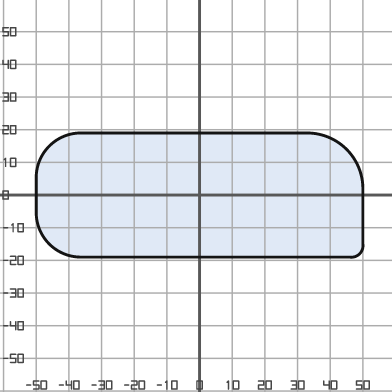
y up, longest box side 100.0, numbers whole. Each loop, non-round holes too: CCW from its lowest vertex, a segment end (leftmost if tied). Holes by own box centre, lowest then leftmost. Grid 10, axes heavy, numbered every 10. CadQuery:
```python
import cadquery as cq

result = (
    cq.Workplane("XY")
    .moveTo(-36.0, -19.0)
    .lineTo(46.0, -19.0)
    .threePointArc((49.0, -18.0), (50.0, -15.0))
    .lineTo(50.0, 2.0)
    .threePointArc((45.0, 14.0), (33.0, 19.0))
    .lineTo(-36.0, 19.0)
    .threePointArc((-46.0, 15.0), (-50.0, 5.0))
    .lineTo(-50.0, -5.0)
    .threePointArc((-46.0, -15.0), (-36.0, -19.0))
    .close()
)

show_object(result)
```